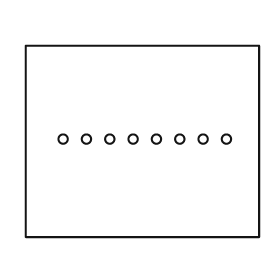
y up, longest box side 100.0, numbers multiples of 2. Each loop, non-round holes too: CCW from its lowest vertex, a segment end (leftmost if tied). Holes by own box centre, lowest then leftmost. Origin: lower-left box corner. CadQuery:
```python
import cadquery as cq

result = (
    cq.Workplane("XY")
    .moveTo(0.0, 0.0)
    .lineTo(100.0, 0.0)
    .lineTo(100.0, 82.0)
    .lineTo(0.0, 82.0)
    .close()
    .moveTo(16.0, 42.0)
    .circle(2.0)
    .moveTo(26.0, 42.0)
    .circle(2.0)
    .moveTo(36.0, 42.0)
    .circle(2.0)
    .moveTo(46.0, 42.0)
    .circle(2.0)
    .moveTo(56.0, 42.0)
    .circle(2.0)
    .moveTo(66.0, 42.0)
    .circle(2.0)
    .moveTo(76.0, 42.0)
    .circle(2.0)
    .moveTo(86.0, 42.0)
    .circle(2.0)
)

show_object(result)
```